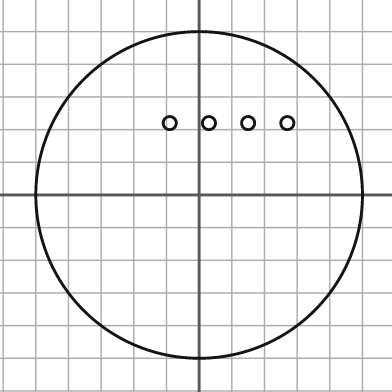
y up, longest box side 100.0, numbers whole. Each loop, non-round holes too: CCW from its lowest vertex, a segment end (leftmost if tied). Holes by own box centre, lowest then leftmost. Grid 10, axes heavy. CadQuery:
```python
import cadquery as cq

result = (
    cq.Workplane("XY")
    .moveTo(0.0, 0.0)
    .circle(50.0)
    .moveTo(-9.0, 22.0)
    .circle(2.0)
    .moveTo(3.0, 22.0)
    .circle(2.0)
    .moveTo(15.0, 22.0)
    .circle(2.0)
    .moveTo(27.0, 22.0)
    .circle(2.0)
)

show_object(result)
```